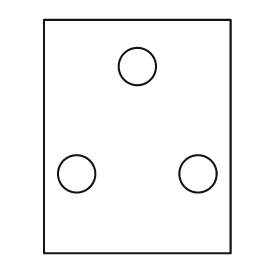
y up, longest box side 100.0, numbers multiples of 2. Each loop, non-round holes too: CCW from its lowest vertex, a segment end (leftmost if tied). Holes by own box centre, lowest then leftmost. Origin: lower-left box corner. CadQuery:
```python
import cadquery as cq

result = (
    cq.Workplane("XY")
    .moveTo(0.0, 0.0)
    .lineTo(80.0, 0.0)
    .lineTo(80.0, 100.0)
    .lineTo(0.0, 100.0)
    .close()
    .moveTo(14.0, 34.0)
    .circle(8.0)
    .moveTo(66.0, 34.0)
    .circle(8.0)
    .moveTo(40.0, 80.0)
    .circle(8.0)
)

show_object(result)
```